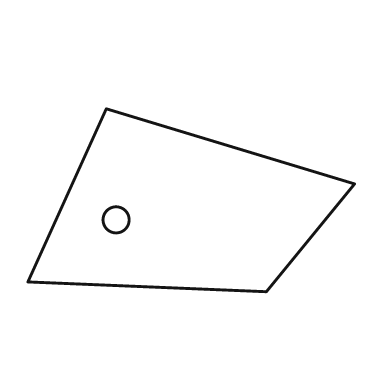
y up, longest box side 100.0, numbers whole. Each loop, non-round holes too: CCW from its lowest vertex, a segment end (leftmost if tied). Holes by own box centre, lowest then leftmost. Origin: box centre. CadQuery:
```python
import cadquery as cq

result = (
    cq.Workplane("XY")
    .moveTo(23.0, -28.0)
    .lineTo(50.0, 5.0)
    .lineTo(-26.0, 28.0)
    .lineTo(-50.0, -25.0)
    .close()
    .moveTo(-23.0, -6.0)
    .circle(4.0)
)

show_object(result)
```